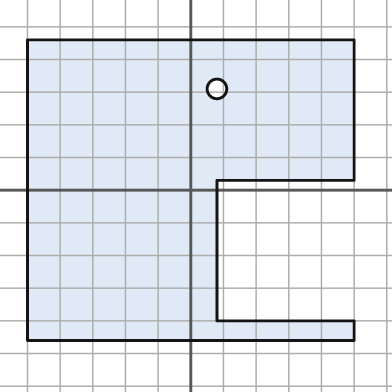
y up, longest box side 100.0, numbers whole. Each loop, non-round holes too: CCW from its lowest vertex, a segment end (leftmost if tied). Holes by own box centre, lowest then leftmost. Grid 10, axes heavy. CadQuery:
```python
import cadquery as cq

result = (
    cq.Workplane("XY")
    .moveTo(-50.0, -46.0)
    .lineTo(50.0, -46.0)
    .lineTo(50.0, -40.0)
    .lineTo(8.0, -40.0)
    .lineTo(8.0, 3.0)
    .lineTo(50.0, 3.0)
    .lineTo(50.0, 46.0)
    .lineTo(-50.0, 46.0)
    .close()
    .moveTo(8.0, 31.0)
    .circle(3.0)
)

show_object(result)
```